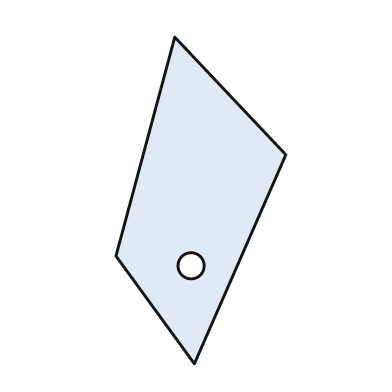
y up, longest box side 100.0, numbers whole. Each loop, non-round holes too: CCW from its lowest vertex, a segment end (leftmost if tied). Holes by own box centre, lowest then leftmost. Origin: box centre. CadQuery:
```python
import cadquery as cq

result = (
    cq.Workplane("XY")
    .moveTo(-2.0, -50.0)
    .lineTo(26.0, 14.0)
    .lineTo(-8.0, 50.0)
    .lineTo(-26.0, -17.0)
    .close()
    .moveTo(-3.0, -20.0)
    .circle(4.0)
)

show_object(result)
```